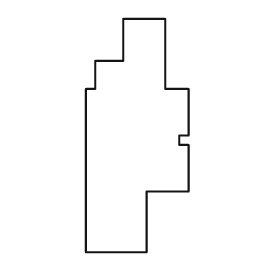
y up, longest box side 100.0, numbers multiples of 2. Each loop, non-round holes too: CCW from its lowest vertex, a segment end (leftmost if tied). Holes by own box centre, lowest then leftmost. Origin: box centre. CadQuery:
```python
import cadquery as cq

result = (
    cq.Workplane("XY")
    .moveTo(-22.0, -50.0)
    .lineTo(4.0, -50.0)
    .lineTo(4.0, -24.0)
    .lineTo(22.0, -24.0)
    .lineTo(22.0, -4.0)
    .lineTo(18.0, -4.0)
    .lineTo(18.0, 0.0)
    .lineTo(22.0, 0.0)
    .lineTo(22.0, 20.0)
    .lineTo(12.0, 20.0)
    .lineTo(12.0, 50.0)
    .lineTo(-6.0, 50.0)
    .lineTo(-6.0, 32.0)
    .lineTo(-18.0, 32.0)
    .lineTo(-18.0, 20.0)
    .lineTo(-22.0, 20.0)
    .close()
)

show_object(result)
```